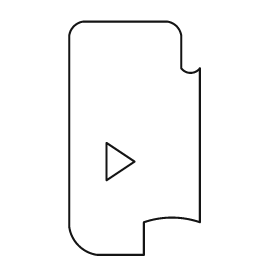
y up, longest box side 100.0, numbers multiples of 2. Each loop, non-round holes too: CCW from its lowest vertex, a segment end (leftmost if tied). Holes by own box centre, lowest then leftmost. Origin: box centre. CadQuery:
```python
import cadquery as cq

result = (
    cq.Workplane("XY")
    .moveTo(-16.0, -50.0)
    .lineTo(4.0, -50.0)
    .lineTo(4.0, -36.0)
    .threePointArc((16.0, -34.0), (28.0, -36.0))
    .lineTo(28.0, 30.0)
    .threePointArc((24.0, 28.0), (20.0, 30.0))
    .lineTo(20.0, 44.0)
    .threePointArc((18.0, 48.0), (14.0, 50.0))
    .lineTo(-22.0, 50.0)
    .threePointArc((-26.0, 48.0), (-28.0, 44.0))
    .lineTo(-28.0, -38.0)
    .threePointArc((-24.0, -46.0), (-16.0, -50.0))
    .close()
    .moveTo(-12.0, -18.0)
    .lineTo(0.0, -10.0)
    .lineTo(-12.0, -2.0)
    .close()
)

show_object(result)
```